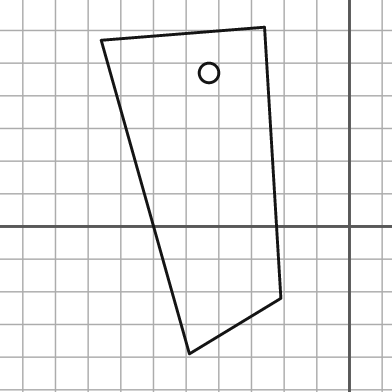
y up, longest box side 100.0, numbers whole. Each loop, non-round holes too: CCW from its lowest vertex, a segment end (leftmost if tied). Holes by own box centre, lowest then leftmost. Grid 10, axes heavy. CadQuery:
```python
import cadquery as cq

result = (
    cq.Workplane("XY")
    .moveTo(-49.0, -39.0)
    .lineTo(-21.0, -22.0)
    .lineTo(-26.0, 61.0)
    .lineTo(-76.0, 57.0)
    .close()
    .moveTo(-43.0, 47.0)
    .circle(3.0)
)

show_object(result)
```